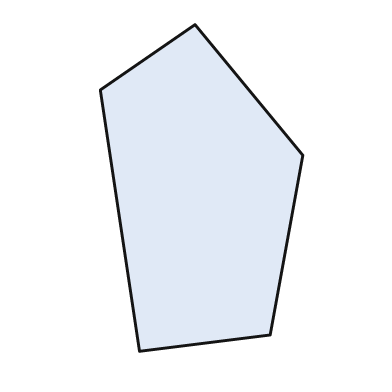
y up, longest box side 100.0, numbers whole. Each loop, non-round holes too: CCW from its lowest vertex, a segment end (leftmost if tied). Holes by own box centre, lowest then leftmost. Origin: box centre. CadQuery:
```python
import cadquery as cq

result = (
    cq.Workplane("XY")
    .moveTo(-19.0, -50.0)
    .lineTo(21.0, -45.0)
    .lineTo(31.0, 10.0)
    .lineTo(-2.0, 50.0)
    .lineTo(-31.0, 30.0)
    .close()
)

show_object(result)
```